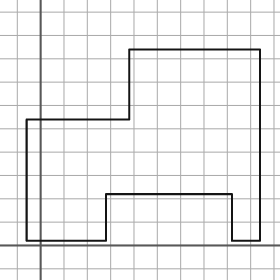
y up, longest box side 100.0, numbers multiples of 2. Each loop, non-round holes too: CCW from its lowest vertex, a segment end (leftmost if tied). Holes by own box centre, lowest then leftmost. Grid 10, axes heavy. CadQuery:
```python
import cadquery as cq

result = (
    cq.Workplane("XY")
    .moveTo(-6.0, 2.0)
    .lineTo(28.0, 2.0)
    .lineTo(28.0, 22.0)
    .lineTo(82.0, 22.0)
    .lineTo(82.0, 2.0)
    .lineTo(94.0, 2.0)
    .lineTo(94.0, 84.0)
    .lineTo(38.0, 84.0)
    .lineTo(38.0, 54.0)
    .lineTo(-6.0, 54.0)
    .close()
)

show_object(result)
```